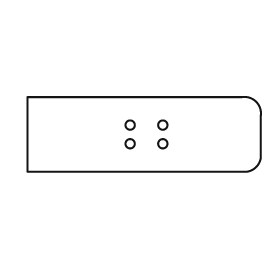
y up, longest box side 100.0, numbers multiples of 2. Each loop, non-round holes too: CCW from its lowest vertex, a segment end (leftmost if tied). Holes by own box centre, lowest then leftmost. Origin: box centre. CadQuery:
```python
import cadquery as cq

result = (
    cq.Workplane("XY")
    .moveTo(-50.0, -16.0)
    .lineTo(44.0, -16.0)
    .threePointArc((48.0, -14.0), (50.0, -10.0))
    .lineTo(50.0, 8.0)
    .threePointArc((48.0, 14.0), (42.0, 16.0))
    .lineTo(-50.0, 16.0)
    .close()
    .moveTo(-6.0, -4.0)
    .circle(2.0)
    .moveTo(8.0, -4.0)
    .circle(2.0)
    .moveTo(-6.0, 4.0)
    .circle(2.0)
    .moveTo(8.0, 4.0)
    .circle(2.0)
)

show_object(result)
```